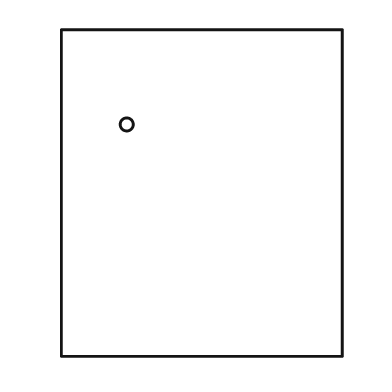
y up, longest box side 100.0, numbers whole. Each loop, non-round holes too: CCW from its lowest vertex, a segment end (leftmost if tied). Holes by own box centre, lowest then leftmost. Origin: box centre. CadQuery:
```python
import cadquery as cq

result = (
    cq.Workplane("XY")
    .moveTo(-43.0, -50.0)
    .lineTo(43.0, -50.0)
    .lineTo(43.0, 50.0)
    .lineTo(-43.0, 50.0)
    .close()
    .moveTo(-23.0, 21.0)
    .circle(2.0)
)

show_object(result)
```